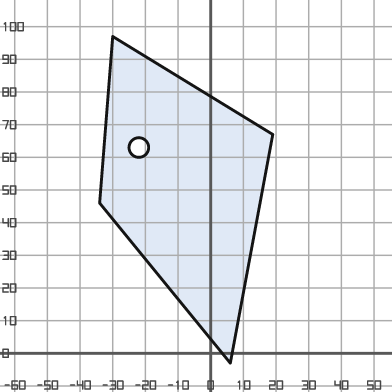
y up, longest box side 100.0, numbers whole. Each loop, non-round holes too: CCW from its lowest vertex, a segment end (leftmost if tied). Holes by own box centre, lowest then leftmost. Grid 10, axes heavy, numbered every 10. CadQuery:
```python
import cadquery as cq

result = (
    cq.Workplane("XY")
    .moveTo(6.0, -3.0)
    .lineTo(19.0, 67.0)
    .lineTo(-30.0, 97.0)
    .lineTo(-34.0, 46.0)
    .close()
    .moveTo(-22.0, 63.0)
    .circle(3.0)
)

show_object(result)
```